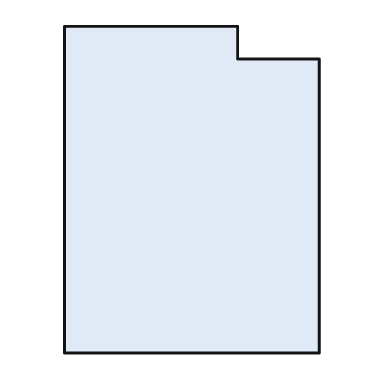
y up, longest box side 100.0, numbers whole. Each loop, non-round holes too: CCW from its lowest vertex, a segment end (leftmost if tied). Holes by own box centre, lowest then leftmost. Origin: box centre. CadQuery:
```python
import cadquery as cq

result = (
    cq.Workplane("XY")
    .moveTo(-39.0, -50.0)
    .lineTo(39.0, -50.0)
    .lineTo(39.0, 40.0)
    .lineTo(14.0, 40.0)
    .lineTo(14.0, 50.0)
    .lineTo(-39.0, 50.0)
    .close()
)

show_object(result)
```